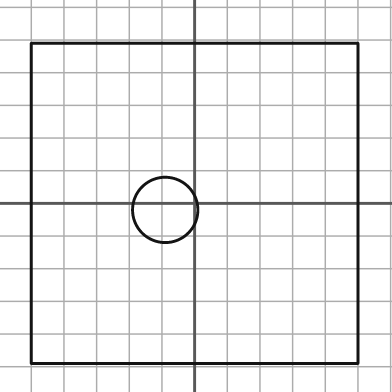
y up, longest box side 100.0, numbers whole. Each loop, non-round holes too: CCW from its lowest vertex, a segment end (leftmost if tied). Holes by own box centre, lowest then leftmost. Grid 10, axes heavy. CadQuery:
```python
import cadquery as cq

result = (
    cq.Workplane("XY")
    .moveTo(-50.0, -49.0)
    .lineTo(50.0, -49.0)
    .lineTo(50.0, 49.0)
    .lineTo(-50.0, 49.0)
    .close()
    .moveTo(-9.0, -2.0)
    .circle(10.0)
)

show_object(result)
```